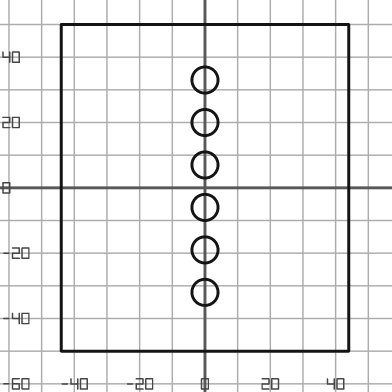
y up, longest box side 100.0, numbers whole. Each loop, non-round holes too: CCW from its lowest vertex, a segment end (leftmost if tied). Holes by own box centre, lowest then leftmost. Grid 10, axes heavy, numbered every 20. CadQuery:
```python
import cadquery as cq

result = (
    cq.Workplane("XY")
    .moveTo(-44.0, -50.0)
    .lineTo(44.0, -50.0)
    .lineTo(44.0, 50.0)
    .lineTo(-44.0, 50.0)
    .close()
    .moveTo(0.0, -32.0)
    .circle(4.0)
    .moveTo(0.0, -19.0)
    .circle(4.0)
    .moveTo(0.0, -6.0)
    .circle(4.0)
    .moveTo(0.0, 7.0)
    .circle(4.0)
    .moveTo(0.0, 20.0)
    .circle(4.0)
    .moveTo(0.0, 33.0)
    .circle(4.0)
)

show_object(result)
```